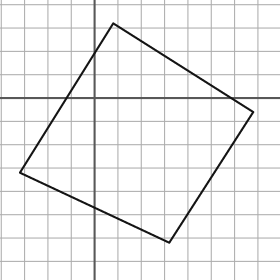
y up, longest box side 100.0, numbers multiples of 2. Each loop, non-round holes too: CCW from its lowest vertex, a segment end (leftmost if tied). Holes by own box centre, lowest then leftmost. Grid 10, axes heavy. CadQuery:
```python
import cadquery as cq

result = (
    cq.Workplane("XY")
    .moveTo(32.0, -62.0)
    .lineTo(68.0, -6.0)
    .lineTo(8.0, 32.0)
    .lineTo(-32.0, -32.0)
    .close()
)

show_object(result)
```